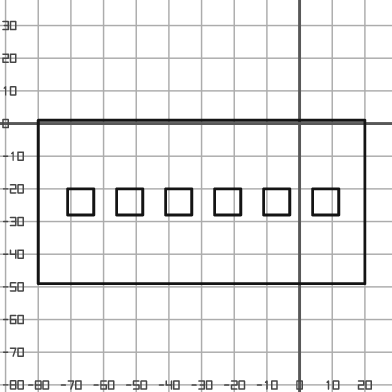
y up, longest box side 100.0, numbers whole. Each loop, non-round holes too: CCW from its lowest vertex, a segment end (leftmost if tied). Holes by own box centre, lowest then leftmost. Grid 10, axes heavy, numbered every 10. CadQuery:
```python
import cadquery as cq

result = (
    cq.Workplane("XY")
    .moveTo(-80.0, -49.0)
    .lineTo(20.0, -49.0)
    .lineTo(20.0, 1.0)
    .lineTo(-80.0, 1.0)
    .close()
    .moveTo(-71.0, -28.0)
    .lineTo(-63.0, -28.0)
    .lineTo(-63.0, -20.0)
    .lineTo(-71.0, -20.0)
    .close()
    .moveTo(-56.0, -28.0)
    .lineTo(-48.0, -28.0)
    .lineTo(-48.0, -20.0)
    .lineTo(-56.0, -20.0)
    .close()
    .moveTo(-41.0, -28.0)
    .lineTo(-33.0, -28.0)
    .lineTo(-33.0, -20.0)
    .lineTo(-41.0, -20.0)
    .close()
    .moveTo(-26.0, -28.0)
    .lineTo(-18.0, -28.0)
    .lineTo(-18.0, -20.0)
    .lineTo(-26.0, -20.0)
    .close()
    .moveTo(-11.0, -28.0)
    .lineTo(-3.0, -28.0)
    .lineTo(-3.0, -20.0)
    .lineTo(-11.0, -20.0)
    .close()
    .moveTo(4.0, -28.0)
    .lineTo(12.0, -28.0)
    .lineTo(12.0, -20.0)
    .lineTo(4.0, -20.0)
    .close()
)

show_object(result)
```